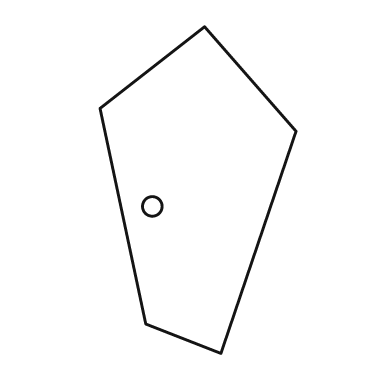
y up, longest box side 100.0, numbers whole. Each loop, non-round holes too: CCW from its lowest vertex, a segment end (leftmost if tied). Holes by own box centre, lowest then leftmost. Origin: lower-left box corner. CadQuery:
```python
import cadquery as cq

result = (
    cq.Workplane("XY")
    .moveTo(37.0, 0.0)
    .lineTo(60.0, 68.0)
    .lineTo(32.0, 100.0)
    .lineTo(0.0, 75.0)
    .lineTo(14.0, 9.0)
    .close()
    .moveTo(16.0, 45.0)
    .circle(3.0)
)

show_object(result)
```